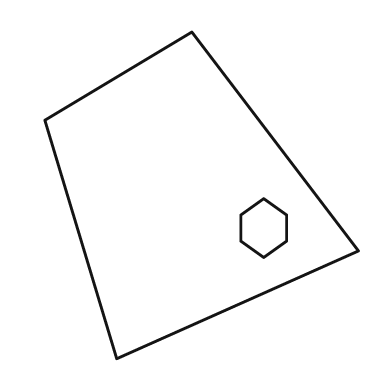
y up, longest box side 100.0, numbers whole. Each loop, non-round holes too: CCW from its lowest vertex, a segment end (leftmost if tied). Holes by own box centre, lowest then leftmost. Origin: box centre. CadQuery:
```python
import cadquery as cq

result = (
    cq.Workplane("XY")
    .moveTo(-26.0, -50.0)
    .lineTo(48.0, -17.0)
    .lineTo(-3.0, 50.0)
    .lineTo(-48.0, 23.0)
    .close()
    .moveTo(19.0, -19.0)
    .lineTo(26.0, -14.0)
    .lineTo(26.0, -6.0)
    .lineTo(19.0, -1.0)
    .lineTo(12.0, -6.0)
    .lineTo(12.0, -14.0)
    .close()
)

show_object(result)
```